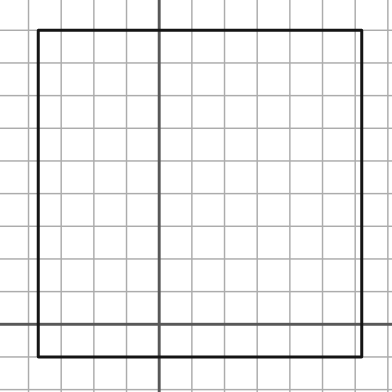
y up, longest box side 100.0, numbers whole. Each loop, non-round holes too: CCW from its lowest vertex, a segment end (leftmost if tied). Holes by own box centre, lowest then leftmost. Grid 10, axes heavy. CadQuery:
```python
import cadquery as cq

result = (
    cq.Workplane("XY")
    .moveTo(-37.0, -10.0)
    .lineTo(62.0, -10.0)
    .lineTo(62.0, 90.0)
    .lineTo(-37.0, 90.0)
    .close()
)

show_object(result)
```